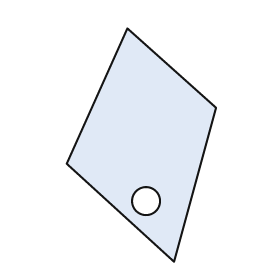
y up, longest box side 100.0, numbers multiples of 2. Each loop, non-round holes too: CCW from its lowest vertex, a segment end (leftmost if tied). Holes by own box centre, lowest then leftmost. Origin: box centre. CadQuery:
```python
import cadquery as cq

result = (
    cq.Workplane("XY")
    .moveTo(14.0, -50.0)
    .lineTo(32.0, 16.0)
    .lineTo(-6.0, 50.0)
    .lineTo(-32.0, -8.0)
    .close()
    .moveTo(2.0, -24.0)
    .circle(6.0)
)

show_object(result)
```